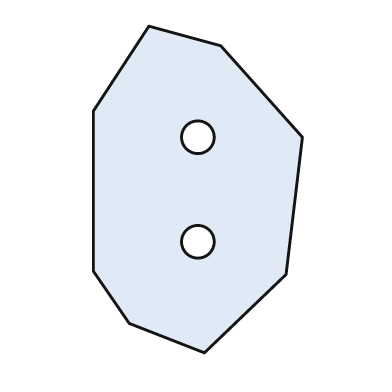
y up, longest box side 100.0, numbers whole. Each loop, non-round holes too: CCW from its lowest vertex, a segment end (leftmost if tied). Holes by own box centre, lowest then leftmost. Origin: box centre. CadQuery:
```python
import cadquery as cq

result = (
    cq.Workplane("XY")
    .moveTo(2.0, -50.0)
    .lineTo(27.0, -26.0)
    .lineTo(32.0, 16.0)
    .lineTo(7.0, 44.0)
    .lineTo(-15.0, 50.0)
    .lineTo(-32.0, 24.0)
    .lineTo(-32.0, -25.0)
    .lineTo(-21.0, -41.0)
    .close()
    .moveTo(0.0, -16.0)
    .circle(5.0)
    .moveTo(0.0, 16.0)
    .circle(5.0)
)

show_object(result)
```